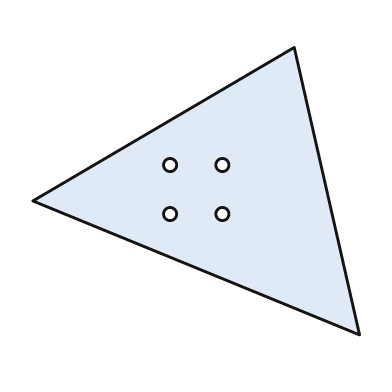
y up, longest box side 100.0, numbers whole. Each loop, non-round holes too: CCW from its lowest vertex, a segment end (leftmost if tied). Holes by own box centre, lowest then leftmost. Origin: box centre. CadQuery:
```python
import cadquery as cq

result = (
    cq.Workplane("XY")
    .moveTo(50.0, -44.0)
    .lineTo(30.0, 44.0)
    .lineTo(-50.0, -3.0)
    .close()
    .moveTo(-8.0, -7.0)
    .circle(2.0)
    .moveTo(8.0, -7.0)
    .circle(2.0)
    .moveTo(-8.0, 8.0)
    .circle(2.0)
    .moveTo(8.0, 8.0)
    .circle(2.0)
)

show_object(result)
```